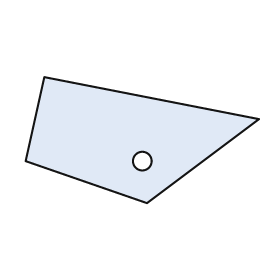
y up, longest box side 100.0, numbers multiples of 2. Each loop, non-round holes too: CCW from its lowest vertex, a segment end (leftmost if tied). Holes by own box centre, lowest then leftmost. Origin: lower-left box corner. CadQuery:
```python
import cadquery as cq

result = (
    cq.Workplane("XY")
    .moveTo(52.0, 0.0)
    .lineTo(100.0, 36.0)
    .lineTo(8.0, 54.0)
    .lineTo(0.0, 18.0)
    .close()
    .moveTo(50.0, 18.0)
    .circle(4.0)
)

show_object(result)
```